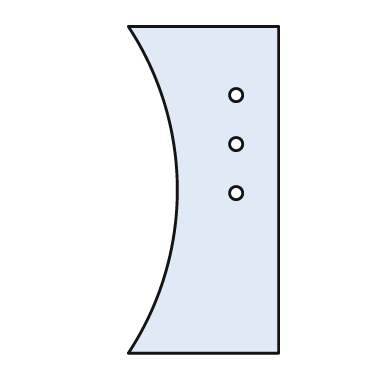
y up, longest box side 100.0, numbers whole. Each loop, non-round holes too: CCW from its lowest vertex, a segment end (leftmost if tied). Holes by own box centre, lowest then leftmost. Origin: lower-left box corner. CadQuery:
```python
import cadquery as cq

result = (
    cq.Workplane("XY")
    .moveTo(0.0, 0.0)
    .lineTo(46.0, 0.0)
    .lineTo(46.0, 100.0)
    .lineTo(0.0, 100.0)
    .threePointArc((15.0, 50.0), (0.0, 0.0))
    .close()
    .moveTo(33.0, 49.0)
    .circle(2.0)
    .moveTo(33.0, 64.0)
    .circle(2.0)
    .moveTo(33.0, 79.0)
    .circle(2.0)
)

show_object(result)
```